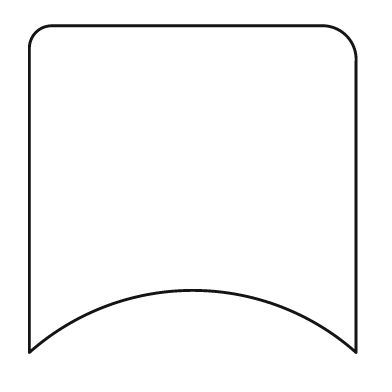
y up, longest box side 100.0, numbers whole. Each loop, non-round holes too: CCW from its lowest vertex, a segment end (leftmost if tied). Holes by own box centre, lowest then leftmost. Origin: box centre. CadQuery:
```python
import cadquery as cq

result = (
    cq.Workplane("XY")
    .moveTo(-50.0, -50.0)
    .threePointArc((0.0, -31.0), (50.0, -50.0))
    .lineTo(50.0, 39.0)
    .threePointArc((47.0, 47.0), (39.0, 50.0))
    .lineTo(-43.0, 50.0)
    .threePointArc((-48.0, 48.0), (-50.0, 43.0))
    .close()
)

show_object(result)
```